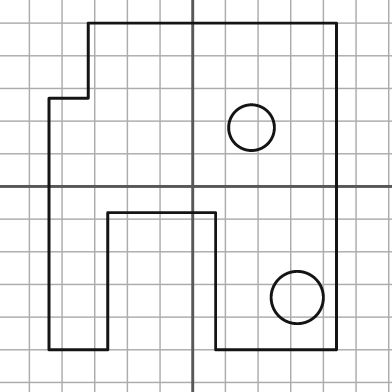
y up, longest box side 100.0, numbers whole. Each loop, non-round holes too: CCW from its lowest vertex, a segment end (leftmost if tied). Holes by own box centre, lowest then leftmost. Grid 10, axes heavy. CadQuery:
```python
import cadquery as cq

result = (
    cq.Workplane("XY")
    .moveTo(-44.0, -50.0)
    .lineTo(-26.0, -50.0)
    .lineTo(-26.0, -8.0)
    .lineTo(7.0, -8.0)
    .lineTo(7.0, -50.0)
    .lineTo(44.0, -50.0)
    .lineTo(44.0, 50.0)
    .lineTo(-32.0, 50.0)
    .lineTo(-32.0, 27.0)
    .lineTo(-44.0, 27.0)
    .close()
    .moveTo(32.0, -34.0)
    .circle(8.0)
    .moveTo(18.0, 18.0)
    .circle(7.0)
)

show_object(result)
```